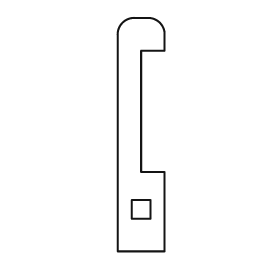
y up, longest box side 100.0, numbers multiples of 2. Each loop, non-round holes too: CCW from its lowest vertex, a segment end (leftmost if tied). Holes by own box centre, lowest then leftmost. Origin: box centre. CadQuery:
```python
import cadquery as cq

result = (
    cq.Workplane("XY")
    .moveTo(-10.0, -50.0)
    .lineTo(10.0, -50.0)
    .lineTo(10.0, -16.0)
    .lineTo(0.0, -16.0)
    .lineTo(0.0, 36.0)
    .lineTo(10.0, 36.0)
    .lineTo(10.0, 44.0)
    .threePointArc((8.0, 48.0), (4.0, 50.0))
    .lineTo(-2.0, 50.0)
    .threePointArc((-8.0, 48.0), (-10.0, 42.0))
    .close()
    .moveTo(-4.0, -36.0)
    .lineTo(4.0, -36.0)
    .lineTo(4.0, -28.0)
    .lineTo(-4.0, -28.0)
    .close()
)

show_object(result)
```